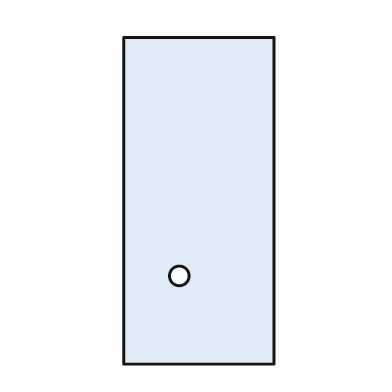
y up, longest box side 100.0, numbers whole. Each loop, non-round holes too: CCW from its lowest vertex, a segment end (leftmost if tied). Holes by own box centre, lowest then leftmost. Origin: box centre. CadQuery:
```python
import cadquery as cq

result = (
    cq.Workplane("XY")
    .moveTo(-23.0, -50.0)
    .lineTo(23.0, -50.0)
    .lineTo(23.0, 50.0)
    .lineTo(-23.0, 50.0)
    .close()
    .moveTo(-6.0, -23.0)
    .circle(3.0)
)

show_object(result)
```